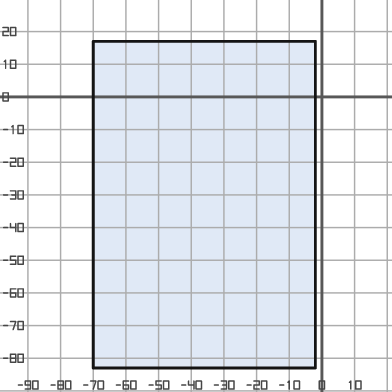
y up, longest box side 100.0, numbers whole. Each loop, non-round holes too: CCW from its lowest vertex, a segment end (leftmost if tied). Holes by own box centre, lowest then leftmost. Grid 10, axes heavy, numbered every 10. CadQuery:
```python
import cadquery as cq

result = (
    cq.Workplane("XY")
    .moveTo(-70.0, -83.0)
    .lineTo(-2.0, -83.0)
    .lineTo(-2.0, 17.0)
    .lineTo(-70.0, 17.0)
    .close()
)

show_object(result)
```